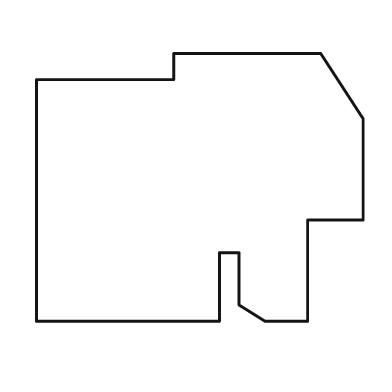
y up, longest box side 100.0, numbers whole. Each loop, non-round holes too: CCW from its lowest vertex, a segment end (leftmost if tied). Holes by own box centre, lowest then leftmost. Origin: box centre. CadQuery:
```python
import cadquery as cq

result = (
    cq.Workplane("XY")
    .moveTo(-50.0, -41.0)
    .lineTo(6.0, -41.0)
    .lineTo(6.0, -20.0)
    .lineTo(12.0, -20.0)
    .lineTo(12.0, -36.0)
    .lineTo(20.0, -41.0)
    .lineTo(33.0, -41.0)
    .lineTo(33.0, -10.0)
    .lineTo(50.0, -10.0)
    .lineTo(50.0, 21.0)
    .lineTo(37.0, 41.0)
    .lineTo(-8.0, 41.0)
    .lineTo(-8.0, 33.0)
    .lineTo(-50.0, 33.0)
    .close()
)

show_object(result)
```